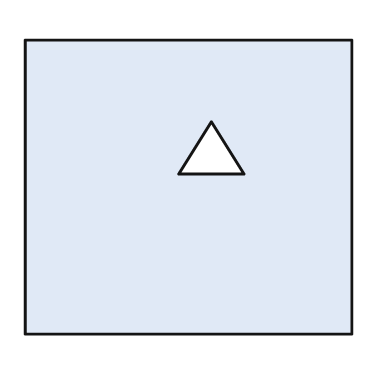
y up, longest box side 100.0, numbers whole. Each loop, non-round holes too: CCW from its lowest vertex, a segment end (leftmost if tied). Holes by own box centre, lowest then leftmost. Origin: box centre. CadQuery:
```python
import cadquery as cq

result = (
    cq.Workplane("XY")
    .moveTo(-50.0, -45.0)
    .lineTo(50.0, -45.0)
    .lineTo(50.0, 45.0)
    .lineTo(-50.0, 45.0)
    .close()
    .moveTo(-3.0, 4.0)
    .lineTo(17.0, 4.0)
    .lineTo(7.0, 20.0)
    .close()
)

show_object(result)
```